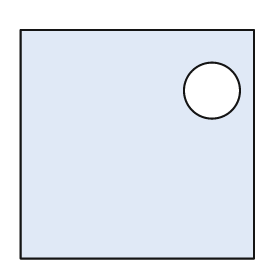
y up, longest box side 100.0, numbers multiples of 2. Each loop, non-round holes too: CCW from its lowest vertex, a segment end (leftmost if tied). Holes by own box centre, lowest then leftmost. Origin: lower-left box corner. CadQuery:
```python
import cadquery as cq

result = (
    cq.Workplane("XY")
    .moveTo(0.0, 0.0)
    .lineTo(100.0, 0.0)
    .lineTo(100.0, 98.0)
    .lineTo(0.0, 98.0)
    .close()
    .moveTo(82.0, 72.0)
    .circle(12.0)
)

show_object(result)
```